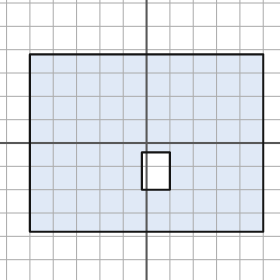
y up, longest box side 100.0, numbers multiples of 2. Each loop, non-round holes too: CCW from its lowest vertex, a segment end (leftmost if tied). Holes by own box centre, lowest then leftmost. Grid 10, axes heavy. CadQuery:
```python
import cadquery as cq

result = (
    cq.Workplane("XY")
    .moveTo(-50.0, -38.0)
    .lineTo(50.0, -38.0)
    .lineTo(50.0, 38.0)
    .lineTo(-50.0, 38.0)
    .close()
    .moveTo(-2.0, -20.0)
    .lineTo(10.0, -20.0)
    .lineTo(10.0, -4.0)
    .lineTo(-2.0, -4.0)
    .close()
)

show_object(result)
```